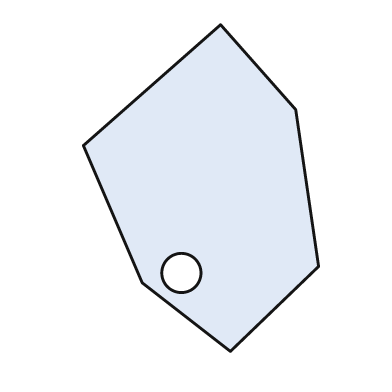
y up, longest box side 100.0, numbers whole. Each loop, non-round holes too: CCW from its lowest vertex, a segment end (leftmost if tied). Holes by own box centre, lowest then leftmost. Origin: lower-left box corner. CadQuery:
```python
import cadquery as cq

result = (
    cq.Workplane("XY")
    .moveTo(45.0, 0.0)
    .lineTo(72.0, 26.0)
    .lineTo(65.0, 74.0)
    .lineTo(42.0, 100.0)
    .lineTo(0.0, 63.0)
    .lineTo(18.0, 21.0)
    .close()
    .moveTo(30.0, 24.0)
    .circle(6.0)
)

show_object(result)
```